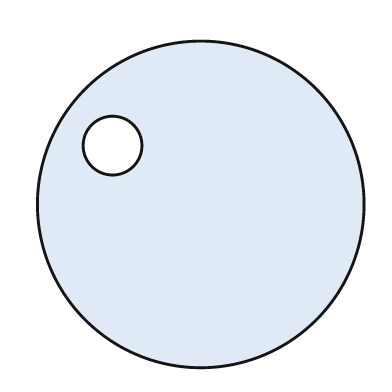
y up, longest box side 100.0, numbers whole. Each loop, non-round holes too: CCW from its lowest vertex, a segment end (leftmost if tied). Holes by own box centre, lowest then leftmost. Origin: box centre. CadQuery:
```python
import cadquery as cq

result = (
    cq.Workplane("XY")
    .moveTo(0.0, 0.0)
    .circle(50.0)
    .moveTo(-27.0, 18.0)
    .circle(9.0)
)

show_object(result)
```